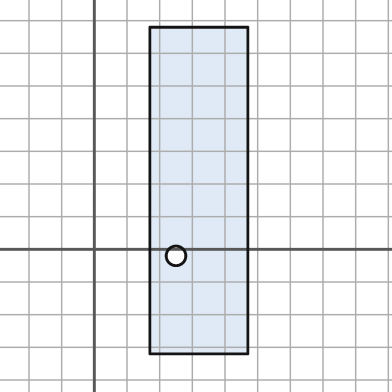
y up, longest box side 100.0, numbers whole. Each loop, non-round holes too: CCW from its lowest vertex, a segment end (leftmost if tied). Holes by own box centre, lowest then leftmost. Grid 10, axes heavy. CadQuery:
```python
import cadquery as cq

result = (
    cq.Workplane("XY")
    .moveTo(17.0, -32.0)
    .lineTo(47.0, -32.0)
    .lineTo(47.0, 68.0)
    .lineTo(17.0, 68.0)
    .close()
    .moveTo(25.0, -2.0)
    .circle(3.0)
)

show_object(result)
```